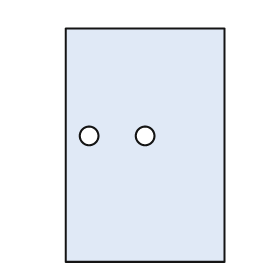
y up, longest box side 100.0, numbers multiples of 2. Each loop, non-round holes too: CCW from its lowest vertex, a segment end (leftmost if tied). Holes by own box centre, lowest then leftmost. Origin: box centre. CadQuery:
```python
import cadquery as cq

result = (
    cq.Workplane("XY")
    .moveTo(-34.0, -50.0)
    .lineTo(34.0, -50.0)
    .lineTo(34.0, 50.0)
    .lineTo(-34.0, 50.0)
    .close()
    .moveTo(-24.0, 4.0)
    .circle(4.0)
    .moveTo(0.0, 4.0)
    .circle(4.0)
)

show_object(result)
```